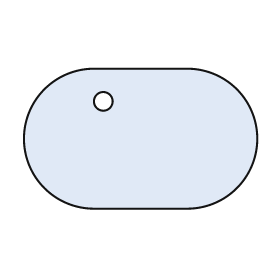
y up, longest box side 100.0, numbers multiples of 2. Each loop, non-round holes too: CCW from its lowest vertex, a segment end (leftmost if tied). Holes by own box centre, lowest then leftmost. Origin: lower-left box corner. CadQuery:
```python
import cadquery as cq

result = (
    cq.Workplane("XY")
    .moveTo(30.0, 0.0)
    .lineTo(70.0, 0.0)
    .threePointArc((100.0, 30.0), (70.0, 60.0))
    .lineTo(30.0, 60.0)
    .threePointArc((0.0, 30.0), (30.0, 0.0))
    .close()
    .moveTo(34.0, 46.0)
    .circle(4.0)
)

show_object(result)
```